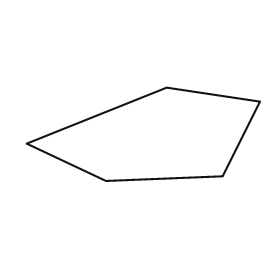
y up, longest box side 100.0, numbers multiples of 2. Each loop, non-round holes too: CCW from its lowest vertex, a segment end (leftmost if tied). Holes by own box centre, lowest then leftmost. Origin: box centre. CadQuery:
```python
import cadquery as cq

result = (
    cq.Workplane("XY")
    .moveTo(-16.0, -20.0)
    .lineTo(34.0, -18.0)
    .lineTo(50.0, 14.0)
    .lineTo(10.0, 20.0)
    .lineTo(-50.0, -4.0)
    .close()
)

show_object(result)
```